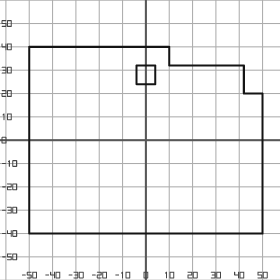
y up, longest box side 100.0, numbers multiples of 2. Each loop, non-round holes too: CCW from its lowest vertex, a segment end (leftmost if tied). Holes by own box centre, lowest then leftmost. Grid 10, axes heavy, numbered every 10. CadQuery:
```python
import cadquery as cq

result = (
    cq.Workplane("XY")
    .moveTo(-50.0, -40.0)
    .lineTo(50.0, -40.0)
    .lineTo(50.0, 20.0)
    .lineTo(42.0, 20.0)
    .lineTo(42.0, 32.0)
    .lineTo(10.0, 32.0)
    .lineTo(10.0, 40.0)
    .lineTo(-50.0, 40.0)
    .close()
    .moveTo(-4.0, 24.0)
    .lineTo(4.0, 24.0)
    .lineTo(4.0, 32.0)
    .lineTo(-4.0, 32.0)
    .close()
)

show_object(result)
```